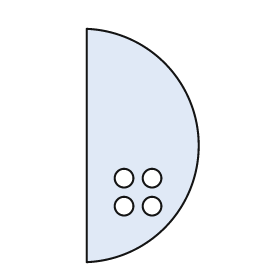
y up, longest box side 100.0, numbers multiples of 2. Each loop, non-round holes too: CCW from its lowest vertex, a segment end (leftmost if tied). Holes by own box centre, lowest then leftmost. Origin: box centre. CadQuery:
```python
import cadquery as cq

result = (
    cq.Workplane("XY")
    .moveTo(-24.0, -50.0)
    .threePointArc((24.0, 0.0), (-24.0, 50.0))
    .close()
    .moveTo(-8.0, -26.0)
    .circle(4.0)
    .moveTo(4.0, -26.0)
    .circle(4.0)
    .moveTo(-8.0, -14.0)
    .circle(4.0)
    .moveTo(4.0, -14.0)
    .circle(4.0)
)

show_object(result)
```